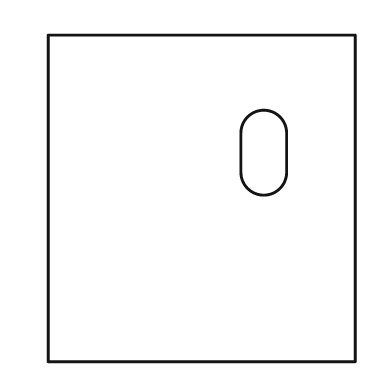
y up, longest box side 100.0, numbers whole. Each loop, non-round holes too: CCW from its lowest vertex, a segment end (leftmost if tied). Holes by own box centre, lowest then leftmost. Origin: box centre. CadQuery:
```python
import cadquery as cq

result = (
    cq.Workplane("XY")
    .moveTo(-47.0, -50.0)
    .lineTo(47.0, -50.0)
    .lineTo(47.0, 50.0)
    .lineTo(-47.0, 50.0)
    .close()
    .moveTo(12.0, 8.0)
    .threePointArc((19.0, 1.0), (26.0, 8.0))
    .lineTo(26.0, 20.0)
    .threePointArc((19.0, 27.0), (12.0, 20.0))
    .close()
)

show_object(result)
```